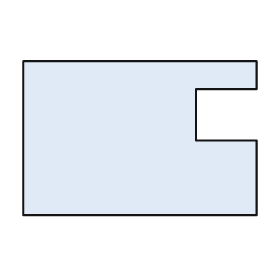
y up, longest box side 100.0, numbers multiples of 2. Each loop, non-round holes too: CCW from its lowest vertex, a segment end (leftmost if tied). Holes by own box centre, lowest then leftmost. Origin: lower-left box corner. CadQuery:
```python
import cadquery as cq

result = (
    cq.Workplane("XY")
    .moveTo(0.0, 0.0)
    .lineTo(100.0, 0.0)
    .lineTo(100.0, 32.0)
    .lineTo(74.0, 32.0)
    .lineTo(74.0, 54.0)
    .lineTo(100.0, 54.0)
    .lineTo(100.0, 66.0)
    .lineTo(0.0, 66.0)
    .close()
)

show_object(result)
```